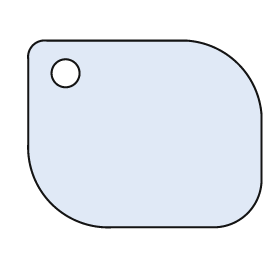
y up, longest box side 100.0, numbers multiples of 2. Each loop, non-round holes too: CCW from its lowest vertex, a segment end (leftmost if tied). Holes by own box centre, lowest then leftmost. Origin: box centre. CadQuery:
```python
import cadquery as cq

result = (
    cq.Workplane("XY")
    .moveTo(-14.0, -40.0)
    .lineTo(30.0, -40.0)
    .threePointArc((44.0, -34.0), (50.0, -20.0))
    .lineTo(50.0, 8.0)
    .threePointArc((40.0, 30.0), (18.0, 40.0))
    .lineTo(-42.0, 40.0)
    .threePointArc((-48.0, 38.0), (-50.0, 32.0))
    .lineTo(-50.0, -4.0)
    .threePointArc((-40.0, -30.0), (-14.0, -40.0))
    .close()
    .moveTo(-34.0, 26.0)
    .circle(6.0)
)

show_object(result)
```